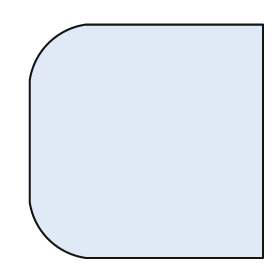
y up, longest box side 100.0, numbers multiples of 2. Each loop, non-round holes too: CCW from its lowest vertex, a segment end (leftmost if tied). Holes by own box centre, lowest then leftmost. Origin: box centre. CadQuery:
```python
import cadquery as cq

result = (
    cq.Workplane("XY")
    .moveTo(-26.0, -50.0)
    .lineTo(50.0, -50.0)
    .lineTo(50.0, 50.0)
    .lineTo(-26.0, 50.0)
    .threePointArc((-42.0, 42.0), (-50.0, 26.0))
    .lineTo(-50.0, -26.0)
    .threePointArc((-42.0, -42.0), (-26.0, -50.0))
    .close()
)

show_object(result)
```